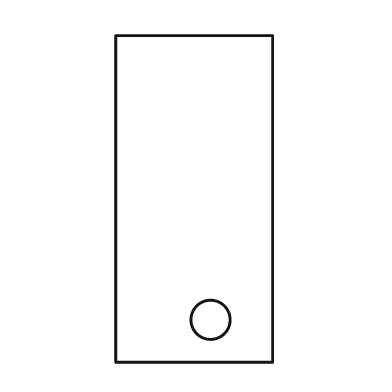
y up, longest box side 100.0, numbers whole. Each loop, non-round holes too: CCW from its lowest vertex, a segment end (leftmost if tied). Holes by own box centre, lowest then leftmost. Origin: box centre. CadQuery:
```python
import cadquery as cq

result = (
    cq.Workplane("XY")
    .moveTo(-24.0, -50.0)
    .lineTo(24.0, -50.0)
    .lineTo(24.0, 50.0)
    .lineTo(-24.0, 50.0)
    .close()
    .moveTo(5.0, -37.0)
    .circle(6.0)
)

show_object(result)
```